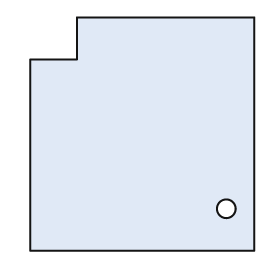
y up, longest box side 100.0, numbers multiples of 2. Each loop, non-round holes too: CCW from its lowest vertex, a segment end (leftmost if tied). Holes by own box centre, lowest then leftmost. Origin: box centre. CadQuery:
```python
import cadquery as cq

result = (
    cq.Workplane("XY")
    .moveTo(-48.0, -50.0)
    .lineTo(48.0, -50.0)
    .lineTo(48.0, 50.0)
    .lineTo(-28.0, 50.0)
    .lineTo(-28.0, 32.0)
    .lineTo(-48.0, 32.0)
    .close()
    .moveTo(36.0, -32.0)
    .circle(4.0)
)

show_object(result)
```